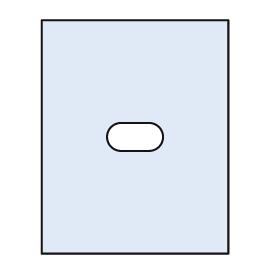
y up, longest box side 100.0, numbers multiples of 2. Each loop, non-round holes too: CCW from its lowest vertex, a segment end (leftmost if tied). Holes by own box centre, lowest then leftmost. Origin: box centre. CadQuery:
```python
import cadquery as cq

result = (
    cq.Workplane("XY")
    .moveTo(-40.0, -50.0)
    .lineTo(40.0, -50.0)
    .lineTo(40.0, 50.0)
    .lineTo(-40.0, 50.0)
    .close()
    .moveTo(-6.0, -6.0)
    .lineTo(6.0, -6.0)
    .threePointArc((12.0, 0.0), (6.0, 6.0))
    .lineTo(-6.0, 6.0)
    .threePointArc((-12.0, 0.0), (-6.0, -6.0))
    .close()
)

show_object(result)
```